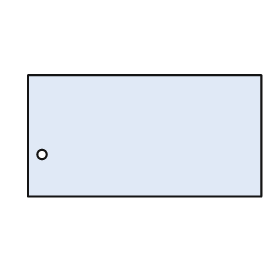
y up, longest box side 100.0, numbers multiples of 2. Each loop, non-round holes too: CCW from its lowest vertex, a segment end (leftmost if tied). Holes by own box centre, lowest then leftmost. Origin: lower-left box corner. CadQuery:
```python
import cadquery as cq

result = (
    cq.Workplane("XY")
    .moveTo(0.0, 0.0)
    .lineTo(100.0, 0.0)
    .lineTo(100.0, 52.0)
    .lineTo(0.0, 52.0)
    .close()
    .moveTo(6.0, 18.0)
    .circle(2.0)
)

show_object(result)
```